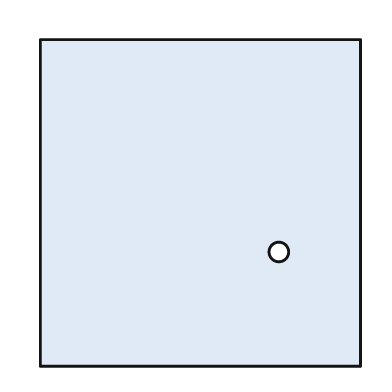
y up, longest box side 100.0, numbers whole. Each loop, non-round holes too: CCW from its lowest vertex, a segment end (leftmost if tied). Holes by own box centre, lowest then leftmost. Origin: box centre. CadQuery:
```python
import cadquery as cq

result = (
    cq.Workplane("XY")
    .moveTo(-49.0, -50.0)
    .lineTo(49.0, -50.0)
    .lineTo(49.0, 50.0)
    .lineTo(-49.0, 50.0)
    .close()
    .moveTo(24.0, -15.0)
    .circle(3.0)
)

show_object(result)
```